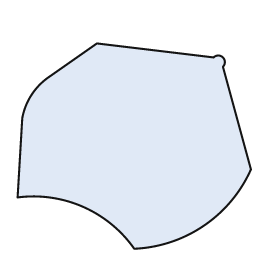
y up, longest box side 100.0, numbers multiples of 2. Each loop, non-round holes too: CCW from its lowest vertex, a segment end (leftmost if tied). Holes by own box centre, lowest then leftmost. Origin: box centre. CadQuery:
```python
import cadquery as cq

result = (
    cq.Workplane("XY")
    .moveTo(0.0, -44.0)
    .threePointArc((30.0, -34.0), (50.0, -10.0))
    .lineTo(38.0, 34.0)
    .threePointArc((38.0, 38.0), (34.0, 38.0))
    .lineTo(-16.0, 44.0)
    .lineTo(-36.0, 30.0)
    .threePointArc((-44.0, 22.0), (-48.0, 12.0))
    .lineTo(-50.0, -22.0)
    .threePointArc((-22.0, -26.0), (0.0, -44.0))
    .close()
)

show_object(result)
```